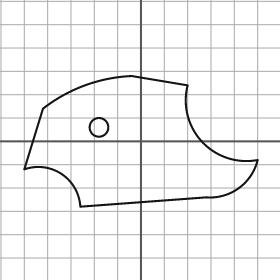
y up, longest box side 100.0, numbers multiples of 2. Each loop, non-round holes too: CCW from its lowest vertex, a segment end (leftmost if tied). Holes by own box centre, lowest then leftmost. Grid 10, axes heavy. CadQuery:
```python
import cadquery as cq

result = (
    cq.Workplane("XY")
    .moveTo(-26.0, -28.0)
    .lineTo(28.0, -24.0)
    .threePointArc((42.0, -20.0), (50.0, -8.0))
    .threePointArc((26.0, 0.0), (20.0, 24.0))
    .lineTo(-4.0, 28.0)
    .threePointArc((-24.0, 24.0), (-42.0, 14.0))
    .lineTo(-50.0, -12.0)
    .threePointArc((-34.0, -14.0), (-26.0, -28.0))
    .close()
    .moveTo(-18.0, 6.0)
    .circle(4.0)
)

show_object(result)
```